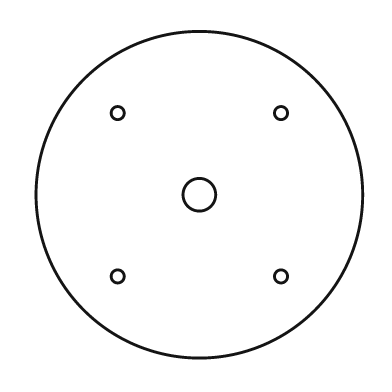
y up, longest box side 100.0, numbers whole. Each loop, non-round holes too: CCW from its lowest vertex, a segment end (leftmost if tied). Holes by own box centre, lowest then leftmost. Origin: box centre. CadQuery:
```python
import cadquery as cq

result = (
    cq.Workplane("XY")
    .moveTo(0.0, 0.0)
    .circle(50.0)
    .moveTo(-25.0, -25.0)
    .circle(2.0)
    .moveTo(25.0, -25.0)
    .circle(2.0)
    .moveTo(0.0, 0.0)
    .circle(5.0)
    .moveTo(-25.0, 25.0)
    .circle(2.0)
    .moveTo(25.0, 25.0)
    .circle(2.0)
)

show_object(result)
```